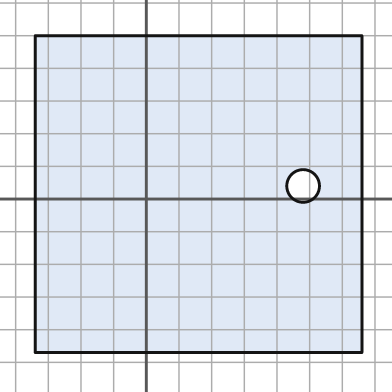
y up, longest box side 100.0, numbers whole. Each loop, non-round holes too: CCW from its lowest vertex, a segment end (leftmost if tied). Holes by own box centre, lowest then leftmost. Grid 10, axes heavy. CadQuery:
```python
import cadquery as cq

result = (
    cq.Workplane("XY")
    .moveTo(-34.0, -47.0)
    .lineTo(66.0, -47.0)
    .lineTo(66.0, 50.0)
    .lineTo(-34.0, 50.0)
    .close()
    .moveTo(48.0, 4.0)
    .circle(5.0)
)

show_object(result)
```